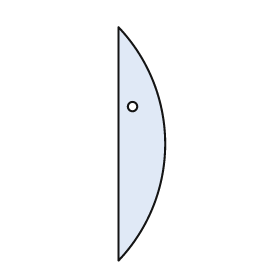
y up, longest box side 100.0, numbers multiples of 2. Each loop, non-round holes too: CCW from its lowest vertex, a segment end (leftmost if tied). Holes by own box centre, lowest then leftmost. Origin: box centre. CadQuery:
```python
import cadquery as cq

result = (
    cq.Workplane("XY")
    .moveTo(-10.0, -50.0)
    .threePointArc((10.0, 0.0), (-10.0, 50.0))
    .close()
    .moveTo(-4.0, 16.0)
    .circle(2.0)
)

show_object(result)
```